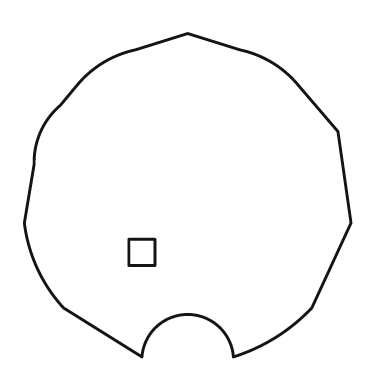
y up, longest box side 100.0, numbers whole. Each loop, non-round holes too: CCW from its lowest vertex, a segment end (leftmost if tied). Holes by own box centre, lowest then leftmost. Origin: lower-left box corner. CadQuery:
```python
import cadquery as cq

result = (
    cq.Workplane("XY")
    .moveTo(36.0, 0.0)
    .threePointArc((50.0, 13.0), (64.0, 0.0))
    .threePointArc((77.0, 6.0), (88.0, 15.0))
    .lineTo(100.0, 41.0)
    .lineTo(96.0, 69.0)
    .lineTo(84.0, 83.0)
    .threePointArc((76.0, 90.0), (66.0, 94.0))
    .lineTo(50.0, 99.0)
    .lineTo(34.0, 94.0)
    .threePointArc((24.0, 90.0), (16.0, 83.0))
    .lineTo(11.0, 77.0)
    .threePointArc((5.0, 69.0), (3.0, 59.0))
    .lineTo(0.0, 41.0)
    .threePointArc((4.0, 27.0), (12.0, 15.0))
    .close()
    .moveTo(32.0, 28.0)
    .lineTo(40.0, 28.0)
    .lineTo(40.0, 36.0)
    .lineTo(32.0, 36.0)
    .close()
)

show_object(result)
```